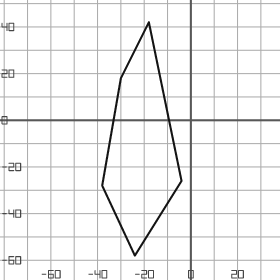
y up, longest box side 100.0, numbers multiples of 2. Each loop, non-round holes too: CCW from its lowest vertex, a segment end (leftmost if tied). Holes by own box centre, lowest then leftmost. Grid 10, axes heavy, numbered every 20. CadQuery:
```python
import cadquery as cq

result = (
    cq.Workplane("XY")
    .moveTo(-24.0, -58.0)
    .lineTo(-4.0, -26.0)
    .lineTo(-18.0, 42.0)
    .lineTo(-30.0, 18.0)
    .lineTo(-38.0, -28.0)
    .close()
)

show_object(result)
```